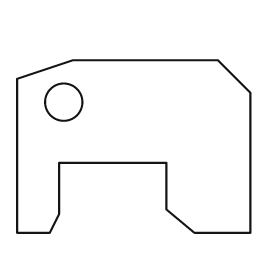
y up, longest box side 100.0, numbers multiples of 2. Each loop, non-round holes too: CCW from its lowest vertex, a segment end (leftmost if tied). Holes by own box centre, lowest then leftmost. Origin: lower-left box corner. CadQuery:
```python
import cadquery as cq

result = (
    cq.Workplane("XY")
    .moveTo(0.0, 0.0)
    .lineTo(14.0, 0.0)
    .lineTo(18.0, 8.0)
    .lineTo(18.0, 30.0)
    .lineTo(64.0, 30.0)
    .lineTo(64.0, 10.0)
    .lineTo(76.0, 0.0)
    .lineTo(100.0, 0.0)
    .lineTo(100.0, 60.0)
    .lineTo(86.0, 74.0)
    .lineTo(24.0, 74.0)
    .lineTo(0.0, 66.0)
    .close()
    .moveTo(20.0, 56.0)
    .circle(8.0)
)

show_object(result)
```